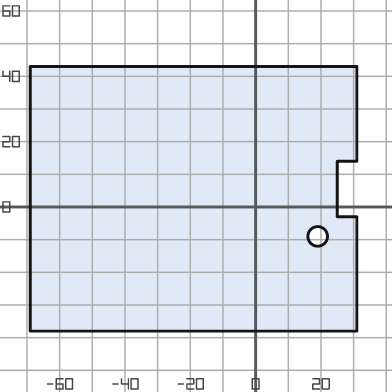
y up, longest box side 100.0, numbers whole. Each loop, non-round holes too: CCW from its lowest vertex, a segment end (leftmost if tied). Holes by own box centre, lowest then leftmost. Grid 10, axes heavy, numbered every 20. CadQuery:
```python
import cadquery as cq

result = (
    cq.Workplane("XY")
    .moveTo(-69.0, -38.0)
    .lineTo(31.0, -38.0)
    .lineTo(31.0, -3.0)
    .lineTo(25.0, -3.0)
    .lineTo(25.0, 14.0)
    .lineTo(31.0, 14.0)
    .lineTo(31.0, 43.0)
    .lineTo(-69.0, 43.0)
    .close()
    .moveTo(19.0, -9.0)
    .circle(3.0)
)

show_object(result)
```